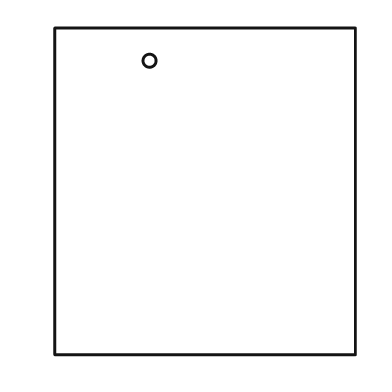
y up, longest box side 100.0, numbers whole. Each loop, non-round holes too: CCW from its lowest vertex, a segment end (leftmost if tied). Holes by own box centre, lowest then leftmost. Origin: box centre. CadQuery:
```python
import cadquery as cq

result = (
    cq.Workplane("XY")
    .moveTo(-46.0, -50.0)
    .lineTo(46.0, -50.0)
    .lineTo(46.0, 50.0)
    .lineTo(-46.0, 50.0)
    .close()
    .moveTo(-17.0, 40.0)
    .circle(2.0)
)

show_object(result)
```